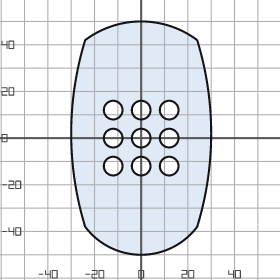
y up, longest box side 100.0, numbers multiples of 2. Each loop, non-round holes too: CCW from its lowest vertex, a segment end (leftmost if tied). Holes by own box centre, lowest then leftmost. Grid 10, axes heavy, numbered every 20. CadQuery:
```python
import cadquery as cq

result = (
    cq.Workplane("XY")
    .moveTo(-24.0, -38.0)
    .threePointArc((0.0, -50.0), (24.0, -38.0))
    .threePointArc((30.0, 2.0), (24.0, 42.0))
    .threePointArc((0.0, 50.0), (-24.0, 42.0))
    .threePointArc((-30.0, 2.0), (-24.0, -38.0))
    .close()
    .moveTo(-12.0, -12.0)
    .circle(4.0)
    .moveTo(0.0, -12.0)
    .circle(4.0)
    .moveTo(12.0, -12.0)
    .circle(4.0)
    .moveTo(-12.0, 0.0)
    .circle(4.0)
    .moveTo(0.0, 0.0)
    .circle(4.0)
    .moveTo(12.0, 0.0)
    .circle(4.0)
    .moveTo(-12.0, 12.0)
    .circle(4.0)
    .moveTo(0.0, 12.0)
    .circle(4.0)
    .moveTo(12.0, 12.0)
    .circle(4.0)
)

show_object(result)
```